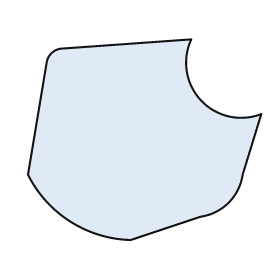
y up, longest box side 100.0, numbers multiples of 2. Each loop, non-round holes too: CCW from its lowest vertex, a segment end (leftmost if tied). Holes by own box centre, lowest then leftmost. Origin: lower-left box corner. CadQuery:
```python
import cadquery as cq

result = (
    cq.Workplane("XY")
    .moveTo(44.0, 0.0)
    .lineTo(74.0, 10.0)
    .threePointArc((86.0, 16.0), (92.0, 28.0))
    .lineTo(100.0, 54.0)
    .threePointArc((74.0, 60.0), (70.0, 86.0))
    .lineTo(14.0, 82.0)
    .threePointArc((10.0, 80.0), (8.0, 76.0))
    .lineTo(0.0, 28.0)
    .threePointArc((18.0, 8.0), (44.0, 0.0))
    .close()
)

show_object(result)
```